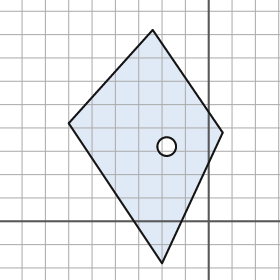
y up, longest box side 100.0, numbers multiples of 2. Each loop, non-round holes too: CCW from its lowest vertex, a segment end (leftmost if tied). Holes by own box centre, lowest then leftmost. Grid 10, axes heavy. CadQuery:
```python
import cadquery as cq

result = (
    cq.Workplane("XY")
    .moveTo(-20.0, -18.0)
    .lineTo(6.0, 38.0)
    .lineTo(-24.0, 82.0)
    .lineTo(-60.0, 42.0)
    .close()
    .moveTo(-18.0, 32.0)
    .circle(4.0)
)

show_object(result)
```